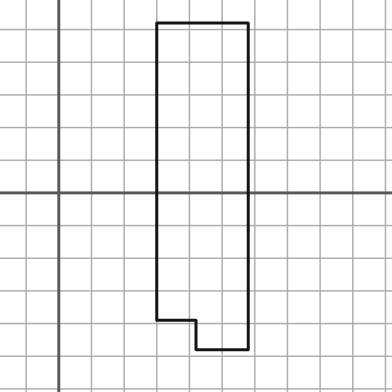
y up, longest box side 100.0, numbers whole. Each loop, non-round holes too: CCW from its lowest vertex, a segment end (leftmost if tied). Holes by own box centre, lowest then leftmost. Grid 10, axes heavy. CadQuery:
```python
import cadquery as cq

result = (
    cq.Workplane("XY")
    .moveTo(42.0, -48.0)
    .lineTo(58.0, -48.0)
    .lineTo(58.0, 52.0)
    .lineTo(30.0, 52.0)
    .lineTo(30.0, -39.0)
    .lineTo(42.0, -39.0)
    .close()
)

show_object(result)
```